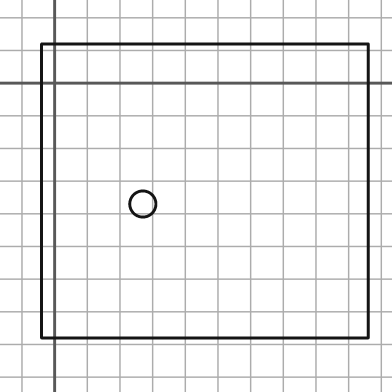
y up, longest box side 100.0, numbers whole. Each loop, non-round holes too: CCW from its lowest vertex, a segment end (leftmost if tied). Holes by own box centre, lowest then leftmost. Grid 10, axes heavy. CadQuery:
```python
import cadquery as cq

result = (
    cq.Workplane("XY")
    .moveTo(-4.0, -78.0)
    .lineTo(96.0, -78.0)
    .lineTo(96.0, 12.0)
    .lineTo(-4.0, 12.0)
    .close()
    .moveTo(27.0, -37.0)
    .circle(4.0)
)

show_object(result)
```